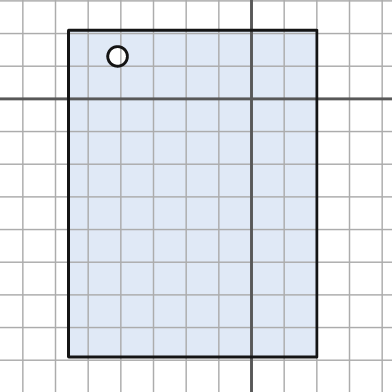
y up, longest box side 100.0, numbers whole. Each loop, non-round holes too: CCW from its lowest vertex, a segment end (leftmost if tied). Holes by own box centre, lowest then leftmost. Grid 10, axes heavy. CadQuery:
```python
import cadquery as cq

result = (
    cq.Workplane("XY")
    .moveTo(-56.0, -79.0)
    .lineTo(20.0, -79.0)
    .lineTo(20.0, 21.0)
    .lineTo(-56.0, 21.0)
    .close()
    .moveTo(-41.0, 13.0)
    .circle(3.0)
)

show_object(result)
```